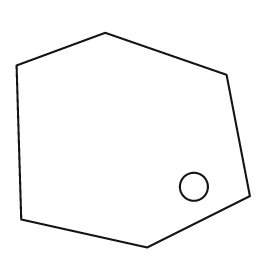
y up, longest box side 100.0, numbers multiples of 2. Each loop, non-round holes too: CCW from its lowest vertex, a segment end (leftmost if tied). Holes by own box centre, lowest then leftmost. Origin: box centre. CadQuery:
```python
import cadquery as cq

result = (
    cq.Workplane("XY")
    .moveTo(6.0, -46.0)
    .lineTo(50.0, -24.0)
    .lineTo(40.0, 28.0)
    .lineTo(-12.0, 46.0)
    .lineTo(-50.0, 32.0)
    .lineTo(-48.0, -34.0)
    .close()
    .moveTo(26.0, -20.0)
    .circle(6.0)
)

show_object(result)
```